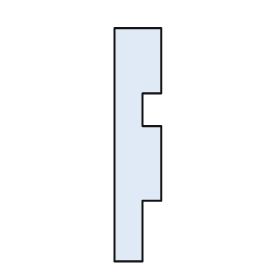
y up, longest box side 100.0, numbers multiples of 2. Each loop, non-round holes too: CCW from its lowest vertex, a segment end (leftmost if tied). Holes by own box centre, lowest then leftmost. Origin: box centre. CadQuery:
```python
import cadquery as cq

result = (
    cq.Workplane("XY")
    .moveTo(-10.0, -50.0)
    .lineTo(2.0, -50.0)
    .lineTo(2.0, -24.0)
    .lineTo(10.0, -24.0)
    .lineTo(10.0, 8.0)
    .lineTo(2.0, 8.0)
    .lineTo(2.0, 22.0)
    .lineTo(10.0, 22.0)
    .lineTo(10.0, 50.0)
    .lineTo(-10.0, 50.0)
    .close()
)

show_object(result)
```